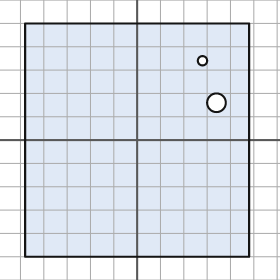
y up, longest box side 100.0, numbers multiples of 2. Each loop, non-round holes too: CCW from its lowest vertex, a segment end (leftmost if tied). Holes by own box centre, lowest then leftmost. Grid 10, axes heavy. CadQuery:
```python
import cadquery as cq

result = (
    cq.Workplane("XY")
    .moveTo(-48.0, -50.0)
    .lineTo(48.0, -50.0)
    .lineTo(48.0, 50.0)
    .lineTo(-48.0, 50.0)
    .close()
    .moveTo(34.0, 16.0)
    .circle(4.0)
    .moveTo(28.0, 34.0)
    .circle(2.0)
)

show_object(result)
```